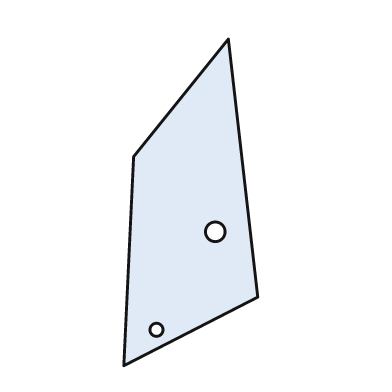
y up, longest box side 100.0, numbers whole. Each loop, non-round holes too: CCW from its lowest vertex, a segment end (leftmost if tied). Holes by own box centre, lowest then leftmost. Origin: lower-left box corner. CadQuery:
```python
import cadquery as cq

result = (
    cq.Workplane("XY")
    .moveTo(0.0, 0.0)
    .lineTo(41.0, 21.0)
    .lineTo(32.0, 100.0)
    .lineTo(3.0, 64.0)
    .close()
    .moveTo(10.0, 11.0)
    .circle(2.0)
    .moveTo(28.0, 41.0)
    .circle(3.0)
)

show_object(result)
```